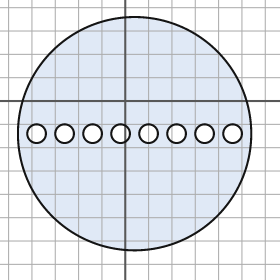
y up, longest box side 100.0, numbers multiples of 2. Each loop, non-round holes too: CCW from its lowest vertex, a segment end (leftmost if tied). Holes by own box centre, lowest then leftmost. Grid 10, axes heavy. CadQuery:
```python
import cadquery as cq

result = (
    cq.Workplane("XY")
    .moveTo(4.0, -14.0)
    .circle(50.0)
    .moveTo(-38.0, -14.0)
    .circle(4.0)
    .moveTo(-26.0, -14.0)
    .circle(4.0)
    .moveTo(-14.0, -14.0)
    .circle(4.0)
    .moveTo(-2.0, -14.0)
    .circle(4.0)
    .moveTo(10.0, -14.0)
    .circle(4.0)
    .moveTo(22.0, -14.0)
    .circle(4.0)
    .moveTo(34.0, -14.0)
    .circle(4.0)
    .moveTo(46.0, -14.0)
    .circle(4.0)
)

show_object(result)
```